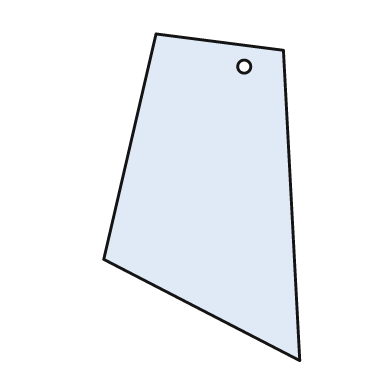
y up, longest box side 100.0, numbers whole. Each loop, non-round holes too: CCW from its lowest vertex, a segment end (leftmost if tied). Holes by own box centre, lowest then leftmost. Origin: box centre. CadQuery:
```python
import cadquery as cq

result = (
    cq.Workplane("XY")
    .moveTo(30.0, -50.0)
    .lineTo(25.0, 45.0)
    .lineTo(-14.0, 50.0)
    .lineTo(-30.0, -19.0)
    .close()
    .moveTo(13.0, 40.0)
    .circle(2.0)
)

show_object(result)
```